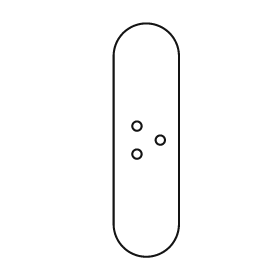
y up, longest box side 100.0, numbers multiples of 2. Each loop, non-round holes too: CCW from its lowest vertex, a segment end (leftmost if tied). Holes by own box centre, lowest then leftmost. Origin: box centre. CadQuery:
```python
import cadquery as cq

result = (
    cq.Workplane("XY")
    .moveTo(-14.0, -36.0)
    .threePointArc((0.0, -50.0), (14.0, -36.0))
    .lineTo(14.0, 36.0)
    .threePointArc((0.0, 50.0), (-14.0, 36.0))
    .close()
    .moveTo(-4.0, -6.0)
    .circle(2.0)
    .moveTo(6.0, 0.0)
    .circle(2.0)
    .moveTo(-4.0, 6.0)
    .circle(2.0)
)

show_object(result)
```